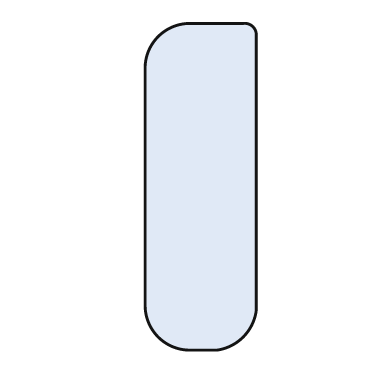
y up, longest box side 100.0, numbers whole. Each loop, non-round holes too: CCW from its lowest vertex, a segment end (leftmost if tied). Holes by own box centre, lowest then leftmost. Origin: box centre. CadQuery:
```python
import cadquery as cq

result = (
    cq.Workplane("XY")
    .moveTo(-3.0, -50.0)
    .lineTo(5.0, -50.0)
    .threePointArc((13.0, -46.0), (17.0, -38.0))
    .lineTo(17.0, 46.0)
    .threePointArc((16.0, 49.0), (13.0, 50.0))
    .lineTo(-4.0, 50.0)
    .threePointArc((-13.0, 46.0), (-17.0, 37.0))
    .lineTo(-17.0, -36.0)
    .threePointArc((-13.0, -46.0), (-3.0, -50.0))
    .close()
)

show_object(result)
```